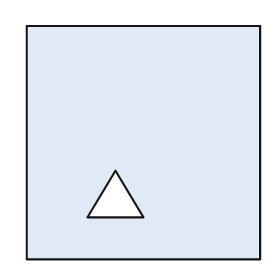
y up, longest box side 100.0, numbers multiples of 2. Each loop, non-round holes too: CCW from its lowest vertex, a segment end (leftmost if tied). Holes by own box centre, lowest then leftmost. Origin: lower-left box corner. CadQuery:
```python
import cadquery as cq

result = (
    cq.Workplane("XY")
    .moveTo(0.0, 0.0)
    .lineTo(100.0, 0.0)
    .lineTo(100.0, 100.0)
    .lineTo(0.0, 100.0)
    .close()
    .moveTo(26.0, 18.0)
    .lineTo(50.0, 18.0)
    .lineTo(38.0, 38.0)
    .close()
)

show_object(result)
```